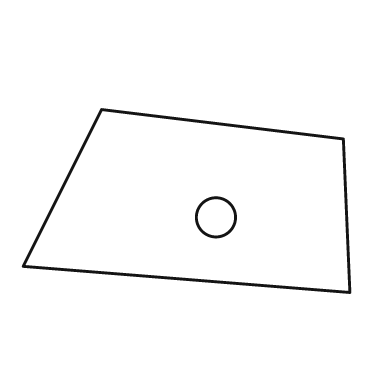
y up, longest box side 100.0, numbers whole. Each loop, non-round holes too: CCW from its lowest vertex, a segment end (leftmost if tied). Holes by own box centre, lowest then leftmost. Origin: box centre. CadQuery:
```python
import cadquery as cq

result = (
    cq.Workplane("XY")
    .moveTo(50.0, -28.0)
    .lineTo(48.0, 19.0)
    .lineTo(-26.0, 28.0)
    .lineTo(-50.0, -20.0)
    .close()
    .moveTo(9.0, -5.0)
    .circle(6.0)
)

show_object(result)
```